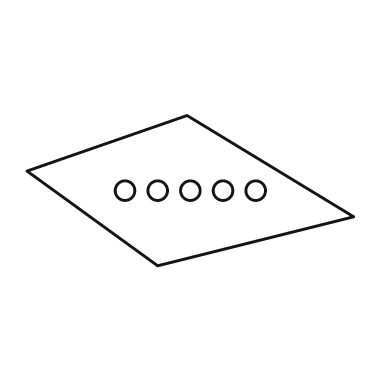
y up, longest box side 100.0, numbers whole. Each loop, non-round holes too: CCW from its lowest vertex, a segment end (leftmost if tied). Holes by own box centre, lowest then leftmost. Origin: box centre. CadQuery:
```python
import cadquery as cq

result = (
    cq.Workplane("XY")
    .moveTo(-10.0, -23.0)
    .lineTo(50.0, -8.0)
    .lineTo(-1.0, 23.0)
    .lineTo(-50.0, 6.0)
    .close()
    .moveTo(-20.0, 0.0)
    .circle(3.0)
    .moveTo(-10.0, 0.0)
    .circle(3.0)
    .moveTo(0.0, 0.0)
    .circle(3.0)
    .moveTo(10.0, 0.0)
    .circle(3.0)
    .moveTo(20.0, 0.0)
    .circle(3.0)
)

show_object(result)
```